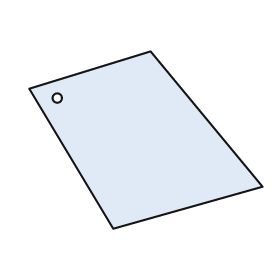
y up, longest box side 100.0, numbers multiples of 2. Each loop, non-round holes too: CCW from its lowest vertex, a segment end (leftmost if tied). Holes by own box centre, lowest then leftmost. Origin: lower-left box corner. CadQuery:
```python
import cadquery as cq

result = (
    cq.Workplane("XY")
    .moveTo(36.0, 0.0)
    .lineTo(100.0, 18.0)
    .lineTo(52.0, 76.0)
    .lineTo(0.0, 60.0)
    .close()
    .moveTo(12.0, 56.0)
    .circle(2.0)
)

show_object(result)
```